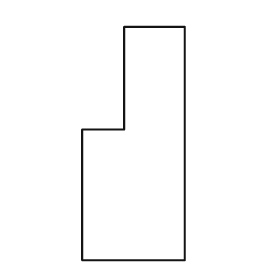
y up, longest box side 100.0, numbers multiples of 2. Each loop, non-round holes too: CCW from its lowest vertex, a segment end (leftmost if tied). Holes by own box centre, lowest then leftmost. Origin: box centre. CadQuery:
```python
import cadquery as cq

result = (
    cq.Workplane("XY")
    .moveTo(-22.0, -50.0)
    .lineTo(22.0, -50.0)
    .lineTo(22.0, 50.0)
    .lineTo(-4.0, 50.0)
    .lineTo(-4.0, 6.0)
    .lineTo(-22.0, 6.0)
    .close()
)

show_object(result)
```